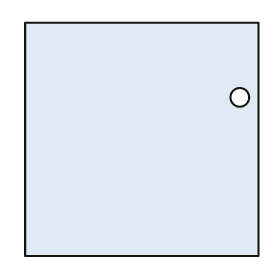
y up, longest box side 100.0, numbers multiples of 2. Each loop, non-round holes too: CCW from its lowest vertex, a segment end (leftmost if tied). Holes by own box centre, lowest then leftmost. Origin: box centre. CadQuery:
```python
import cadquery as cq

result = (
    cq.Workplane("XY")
    .moveTo(-50.0, -50.0)
    .lineTo(50.0, -50.0)
    .lineTo(50.0, 50.0)
    .lineTo(-50.0, 50.0)
    .close()
    .moveTo(42.0, 18.0)
    .circle(4.0)
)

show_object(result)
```